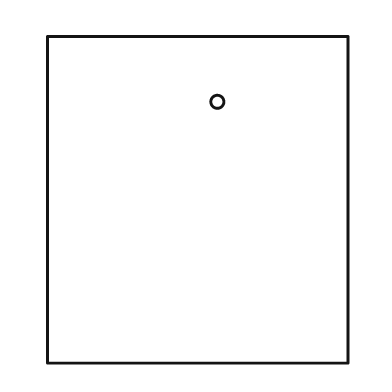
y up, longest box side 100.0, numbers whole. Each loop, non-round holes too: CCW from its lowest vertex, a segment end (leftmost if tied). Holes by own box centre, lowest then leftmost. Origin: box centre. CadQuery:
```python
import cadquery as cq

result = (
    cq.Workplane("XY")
    .moveTo(-46.0, -50.0)
    .lineTo(46.0, -50.0)
    .lineTo(46.0, 50.0)
    .lineTo(-46.0, 50.0)
    .close()
    .moveTo(6.0, 30.0)
    .circle(2.0)
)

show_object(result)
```